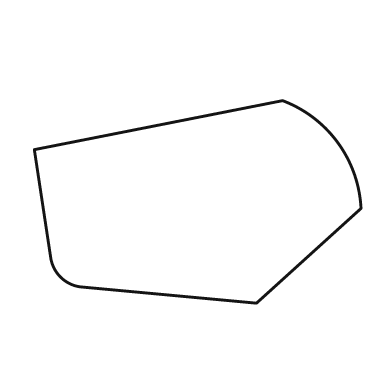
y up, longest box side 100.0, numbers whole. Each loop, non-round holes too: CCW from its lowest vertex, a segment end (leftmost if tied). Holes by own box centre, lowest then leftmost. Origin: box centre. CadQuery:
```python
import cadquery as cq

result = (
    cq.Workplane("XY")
    .moveTo(18.0, -31.0)
    .lineTo(50.0, -2.0)
    .threePointArc((43.0, 18.0), (26.0, 31.0))
    .lineTo(-50.0, 16.0)
    .lineTo(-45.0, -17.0)
    .threePointArc((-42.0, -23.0), (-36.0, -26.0))
    .close()
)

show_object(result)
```